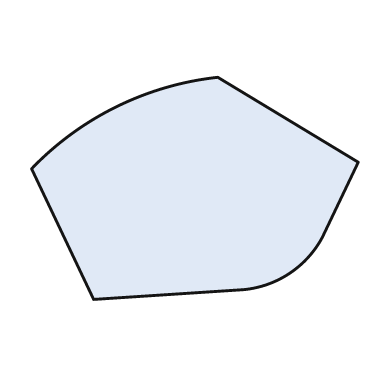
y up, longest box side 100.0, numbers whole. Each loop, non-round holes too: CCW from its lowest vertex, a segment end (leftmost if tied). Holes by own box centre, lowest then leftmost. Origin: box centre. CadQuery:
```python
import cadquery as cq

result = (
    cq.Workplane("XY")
    .moveTo(-31.0, -34.0)
    .lineTo(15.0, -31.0)
    .threePointArc((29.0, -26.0), (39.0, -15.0))
    .lineTo(50.0, 8.0)
    .lineTo(7.0, 34.0)
    .threePointArc((-24.0, 25.0), (-50.0, 6.0))
    .close()
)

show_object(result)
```